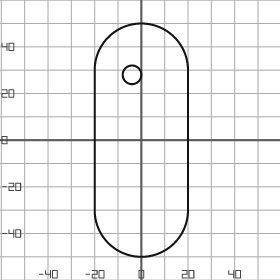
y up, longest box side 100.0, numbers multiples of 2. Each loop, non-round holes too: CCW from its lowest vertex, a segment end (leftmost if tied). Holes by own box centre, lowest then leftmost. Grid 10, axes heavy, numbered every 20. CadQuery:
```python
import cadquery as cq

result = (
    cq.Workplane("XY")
    .moveTo(-20.0, -30.0)
    .threePointArc((0.0, -50.0), (20.0, -30.0))
    .lineTo(20.0, 30.0)
    .threePointArc((0.0, 50.0), (-20.0, 30.0))
    .close()
    .moveTo(-4.0, 28.0)
    .circle(4.0)
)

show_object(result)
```